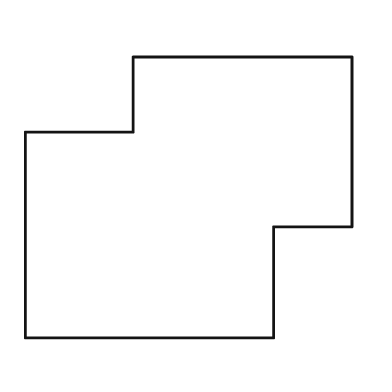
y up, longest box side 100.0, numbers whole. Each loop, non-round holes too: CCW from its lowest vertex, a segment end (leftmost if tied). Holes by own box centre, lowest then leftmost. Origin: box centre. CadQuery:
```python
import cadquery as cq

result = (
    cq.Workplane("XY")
    .moveTo(-50.0, -43.0)
    .lineTo(26.0, -43.0)
    .lineTo(26.0, -9.0)
    .lineTo(50.0, -9.0)
    .lineTo(50.0, 43.0)
    .lineTo(-17.0, 43.0)
    .lineTo(-17.0, 20.0)
    .lineTo(-50.0, 20.0)
    .close()
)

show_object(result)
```